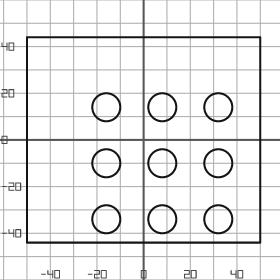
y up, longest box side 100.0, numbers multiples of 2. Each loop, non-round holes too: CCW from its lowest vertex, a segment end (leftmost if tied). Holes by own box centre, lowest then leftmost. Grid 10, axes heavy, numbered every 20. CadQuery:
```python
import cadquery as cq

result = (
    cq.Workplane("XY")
    .moveTo(-50.0, -44.0)
    .lineTo(50.0, -44.0)
    .lineTo(50.0, 44.0)
    .lineTo(-50.0, 44.0)
    .close()
    .moveTo(-16.0, -34.0)
    .circle(6.0)
    .moveTo(8.0, -34.0)
    .circle(6.0)
    .moveTo(32.0, -34.0)
    .circle(6.0)
    .moveTo(-16.0, -10.0)
    .circle(6.0)
    .moveTo(8.0, -10.0)
    .circle(6.0)
    .moveTo(32.0, -10.0)
    .circle(6.0)
    .moveTo(-16.0, 14.0)
    .circle(6.0)
    .moveTo(8.0, 14.0)
    .circle(6.0)
    .moveTo(32.0, 14.0)
    .circle(6.0)
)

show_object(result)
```